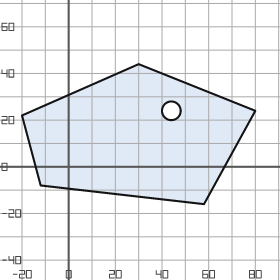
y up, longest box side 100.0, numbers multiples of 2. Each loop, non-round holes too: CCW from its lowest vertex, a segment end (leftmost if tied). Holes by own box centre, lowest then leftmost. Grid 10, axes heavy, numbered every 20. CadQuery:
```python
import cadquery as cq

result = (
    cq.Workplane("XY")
    .moveTo(58.0, -16.0)
    .lineTo(80.0, 24.0)
    .lineTo(30.0, 44.0)
    .lineTo(-20.0, 22.0)
    .lineTo(-12.0, -8.0)
    .close()
    .moveTo(44.0, 24.0)
    .circle(4.0)
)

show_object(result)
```